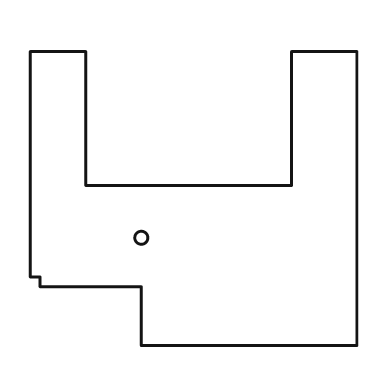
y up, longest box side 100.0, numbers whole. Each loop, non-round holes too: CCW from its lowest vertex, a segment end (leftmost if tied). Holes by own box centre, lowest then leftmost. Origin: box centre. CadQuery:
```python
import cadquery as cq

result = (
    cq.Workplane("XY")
    .moveTo(-16.0, -45.0)
    .lineTo(50.0, -45.0)
    .lineTo(50.0, 45.0)
    .lineTo(30.0, 45.0)
    .lineTo(30.0, 4.0)
    .lineTo(-33.0, 4.0)
    .lineTo(-33.0, 45.0)
    .lineTo(-50.0, 45.0)
    .lineTo(-50.0, -24.0)
    .lineTo(-47.0, -24.0)
    .lineTo(-47.0, -27.0)
    .lineTo(-16.0, -27.0)
    .close()
    .moveTo(-16.0, -12.0)
    .circle(2.0)
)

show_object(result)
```